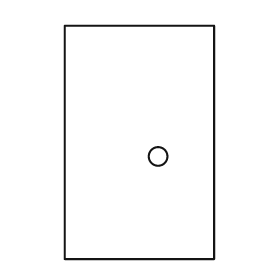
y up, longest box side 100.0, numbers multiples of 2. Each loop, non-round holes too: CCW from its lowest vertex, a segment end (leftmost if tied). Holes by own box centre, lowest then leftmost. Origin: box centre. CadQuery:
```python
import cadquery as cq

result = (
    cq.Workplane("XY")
    .moveTo(-32.0, -50.0)
    .lineTo(32.0, -50.0)
    .lineTo(32.0, 50.0)
    .lineTo(-32.0, 50.0)
    .close()
    .moveTo(8.0, -6.0)
    .circle(4.0)
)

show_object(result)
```